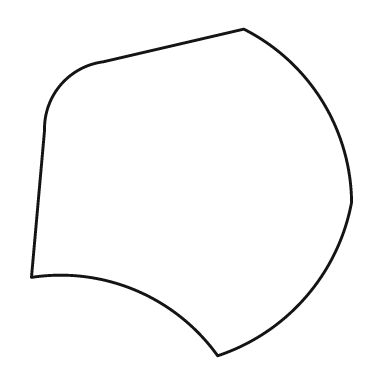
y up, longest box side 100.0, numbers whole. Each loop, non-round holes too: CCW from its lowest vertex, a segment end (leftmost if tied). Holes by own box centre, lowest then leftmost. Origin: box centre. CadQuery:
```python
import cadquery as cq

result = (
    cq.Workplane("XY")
    .moveTo(8.0, -50.0)
    .threePointArc((35.0, -32.0), (49.0, -3.0))
    .threePointArc((40.0, 28.0), (16.0, 50.0))
    .lineTo(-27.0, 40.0)
    .threePointArc((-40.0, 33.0), (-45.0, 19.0))
    .lineTo(-49.0, -26.0)
    .threePointArc((-17.0, -30.0), (8.0, -50.0))
    .close()
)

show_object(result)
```